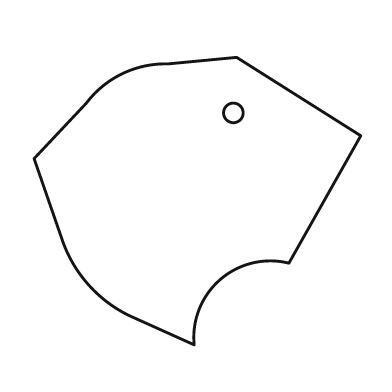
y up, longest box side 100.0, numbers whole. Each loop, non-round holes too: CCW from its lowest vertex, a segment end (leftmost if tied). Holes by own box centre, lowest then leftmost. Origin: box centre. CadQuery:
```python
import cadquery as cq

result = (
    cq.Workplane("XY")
    .moveTo(-1.0, -44.0)
    .threePointArc((7.0, -24.0), (28.0, -19.0))
    .lineTo(50.0, 20.0)
    .lineTo(12.0, 44.0)
    .lineTo(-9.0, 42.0)
    .threePointArc((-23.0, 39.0), (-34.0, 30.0))
    .lineTo(-50.0, 13.0)
    .lineTo(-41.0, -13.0)
    .threePointArc((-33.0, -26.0), (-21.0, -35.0))
    .close()
    .moveTo(11.0, 27.0)
    .circle(3.0)
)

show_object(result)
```